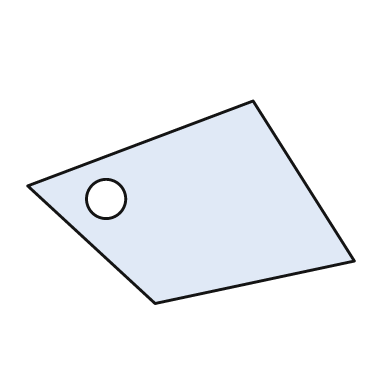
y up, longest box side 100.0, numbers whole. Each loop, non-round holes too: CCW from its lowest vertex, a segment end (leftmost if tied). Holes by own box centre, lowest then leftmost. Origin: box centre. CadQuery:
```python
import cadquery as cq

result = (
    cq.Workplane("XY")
    .moveTo(-11.0, -31.0)
    .lineTo(50.0, -18.0)
    .lineTo(19.0, 31.0)
    .lineTo(-50.0, 5.0)
    .close()
    .moveTo(-26.0, 1.0)
    .circle(6.0)
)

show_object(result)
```